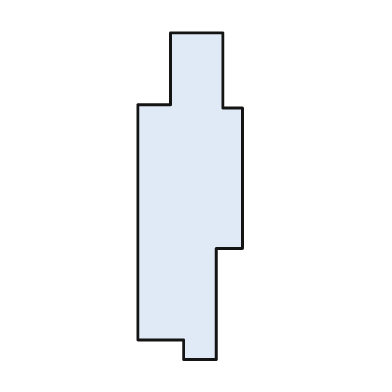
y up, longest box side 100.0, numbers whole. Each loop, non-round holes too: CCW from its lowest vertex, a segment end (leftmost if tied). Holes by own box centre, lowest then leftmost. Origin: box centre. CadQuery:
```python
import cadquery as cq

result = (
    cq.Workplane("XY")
    .moveTo(-2.0, -50.0)
    .lineTo(8.0, -50.0)
    .lineTo(8.0, -16.0)
    .lineTo(16.0, -16.0)
    .lineTo(16.0, 27.0)
    .lineTo(10.0, 27.0)
    .lineTo(10.0, 50.0)
    .lineTo(-6.0, 50.0)
    .lineTo(-6.0, 28.0)
    .lineTo(-16.0, 28.0)
    .lineTo(-16.0, -44.0)
    .lineTo(-2.0, -44.0)
    .close()
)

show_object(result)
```